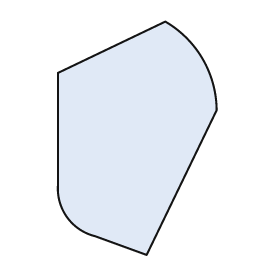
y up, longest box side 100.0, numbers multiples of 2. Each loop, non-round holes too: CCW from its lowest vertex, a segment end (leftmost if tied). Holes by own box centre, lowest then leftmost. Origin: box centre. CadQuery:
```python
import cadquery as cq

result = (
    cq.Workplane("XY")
    .moveTo(4.0, -50.0)
    .lineTo(34.0, 12.0)
    .threePointArc((28.0, 34.0), (12.0, 50.0))
    .lineTo(-34.0, 28.0)
    .lineTo(-34.0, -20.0)
    .threePointArc((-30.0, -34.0), (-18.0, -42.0))
    .close()
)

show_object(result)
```